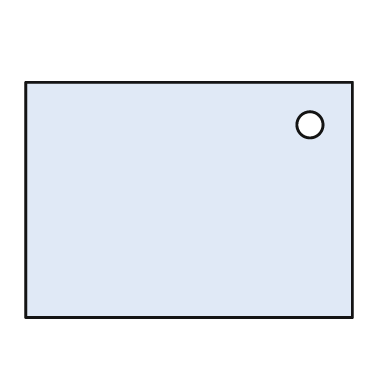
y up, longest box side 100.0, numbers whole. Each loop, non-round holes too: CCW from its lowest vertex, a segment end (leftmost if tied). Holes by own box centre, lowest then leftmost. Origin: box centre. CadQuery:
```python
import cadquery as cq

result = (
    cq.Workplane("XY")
    .moveTo(-50.0, -36.0)
    .lineTo(50.0, -36.0)
    .lineTo(50.0, 36.0)
    .lineTo(-50.0, 36.0)
    .close()
    .moveTo(37.0, 23.0)
    .circle(4.0)
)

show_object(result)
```